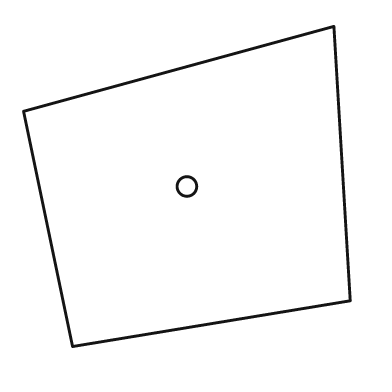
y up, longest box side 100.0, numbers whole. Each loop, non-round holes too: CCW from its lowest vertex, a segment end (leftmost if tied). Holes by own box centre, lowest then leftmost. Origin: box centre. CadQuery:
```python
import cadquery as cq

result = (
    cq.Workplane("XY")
    .moveTo(-35.0, -49.0)
    .lineTo(50.0, -35.0)
    .lineTo(45.0, 49.0)
    .lineTo(-50.0, 23.0)
    .close()
    .moveTo(0.0, 0.0)
    .circle(3.0)
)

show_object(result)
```